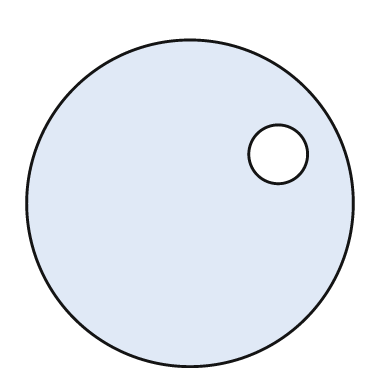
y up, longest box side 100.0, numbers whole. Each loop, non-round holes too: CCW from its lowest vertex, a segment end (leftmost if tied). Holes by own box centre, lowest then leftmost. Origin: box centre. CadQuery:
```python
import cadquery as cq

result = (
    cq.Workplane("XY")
    .moveTo(0.0, 0.0)
    .circle(50.0)
    .moveTo(27.0, 15.0)
    .circle(9.0)
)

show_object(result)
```